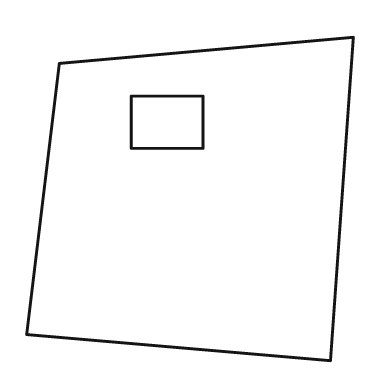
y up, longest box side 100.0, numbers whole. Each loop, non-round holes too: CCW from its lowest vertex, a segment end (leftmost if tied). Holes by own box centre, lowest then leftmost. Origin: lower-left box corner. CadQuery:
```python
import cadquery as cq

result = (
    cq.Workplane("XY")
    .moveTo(93.0, 0.0)
    .lineTo(100.0, 99.0)
    .lineTo(10.0, 91.0)
    .lineTo(0.0, 8.0)
    .close()
    .moveTo(32.0, 65.0)
    .lineTo(54.0, 65.0)
    .lineTo(54.0, 81.0)
    .lineTo(32.0, 81.0)
    .close()
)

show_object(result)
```